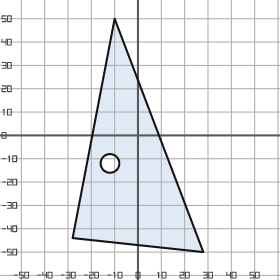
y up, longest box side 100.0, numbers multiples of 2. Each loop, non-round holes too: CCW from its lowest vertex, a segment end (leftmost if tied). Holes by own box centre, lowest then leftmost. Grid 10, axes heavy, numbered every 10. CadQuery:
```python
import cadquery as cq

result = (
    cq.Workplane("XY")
    .moveTo(28.0, -50.0)
    .lineTo(-10.0, 50.0)
    .lineTo(-28.0, -44.0)
    .close()
    .moveTo(-12.0, -12.0)
    .circle(4.0)
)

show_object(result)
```